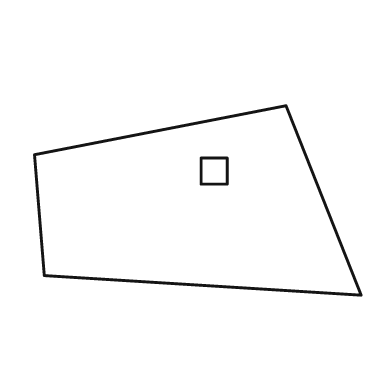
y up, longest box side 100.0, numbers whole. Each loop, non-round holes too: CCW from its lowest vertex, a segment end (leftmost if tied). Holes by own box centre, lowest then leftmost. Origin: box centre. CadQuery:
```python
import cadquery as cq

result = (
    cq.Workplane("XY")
    .moveTo(50.0, -29.0)
    .lineTo(27.0, 29.0)
    .lineTo(-50.0, 14.0)
    .lineTo(-47.0, -23.0)
    .close()
    .moveTo(1.0, 5.0)
    .lineTo(9.0, 5.0)
    .lineTo(9.0, 13.0)
    .lineTo(1.0, 13.0)
    .close()
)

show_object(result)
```